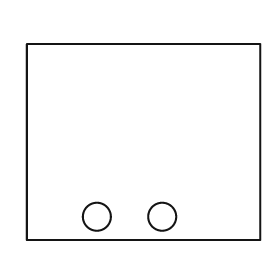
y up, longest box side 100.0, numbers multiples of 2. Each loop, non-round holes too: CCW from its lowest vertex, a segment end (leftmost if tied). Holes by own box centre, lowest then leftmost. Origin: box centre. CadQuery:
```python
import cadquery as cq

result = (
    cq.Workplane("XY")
    .moveTo(-50.0, -42.0)
    .lineTo(50.0, -42.0)
    .lineTo(50.0, 42.0)
    .lineTo(-50.0, 42.0)
    .close()
    .moveTo(-20.0, -32.0)
    .circle(6.0)
    .moveTo(8.0, -32.0)
    .circle(6.0)
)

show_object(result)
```